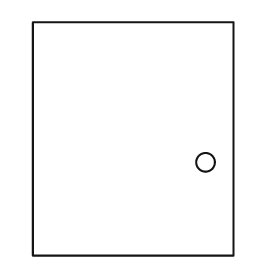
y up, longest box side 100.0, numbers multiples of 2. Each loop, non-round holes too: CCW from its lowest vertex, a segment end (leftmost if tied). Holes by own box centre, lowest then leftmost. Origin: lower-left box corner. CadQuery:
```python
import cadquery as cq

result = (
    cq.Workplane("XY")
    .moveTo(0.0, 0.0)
    .lineTo(86.0, 0.0)
    .lineTo(86.0, 100.0)
    .lineTo(0.0, 100.0)
    .close()
    .moveTo(74.0, 40.0)
    .circle(4.0)
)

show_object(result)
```